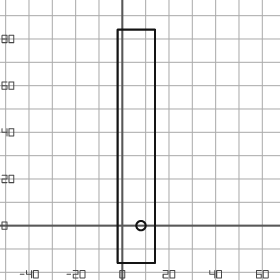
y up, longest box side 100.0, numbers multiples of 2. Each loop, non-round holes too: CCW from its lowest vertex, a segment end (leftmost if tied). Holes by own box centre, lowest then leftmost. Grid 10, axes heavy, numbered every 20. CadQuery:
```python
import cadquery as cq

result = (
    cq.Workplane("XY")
    .moveTo(-2.0, -16.0)
    .lineTo(14.0, -16.0)
    .lineTo(14.0, 84.0)
    .lineTo(-2.0, 84.0)
    .close()
    .moveTo(8.0, 0.0)
    .circle(2.0)
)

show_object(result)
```